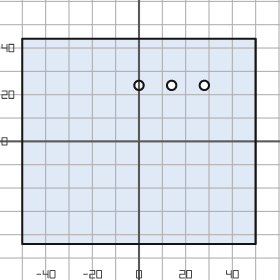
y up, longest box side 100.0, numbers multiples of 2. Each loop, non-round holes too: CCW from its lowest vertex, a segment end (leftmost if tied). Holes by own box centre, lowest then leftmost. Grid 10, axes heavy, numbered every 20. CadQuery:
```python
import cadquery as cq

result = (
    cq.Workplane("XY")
    .moveTo(-50.0, -44.0)
    .lineTo(50.0, -44.0)
    .lineTo(50.0, 44.0)
    .lineTo(-50.0, 44.0)
    .close()
    .moveTo(0.0, 24.0)
    .circle(2.0)
    .moveTo(14.0, 24.0)
    .circle(2.0)
    .moveTo(28.0, 24.0)
    .circle(2.0)
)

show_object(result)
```